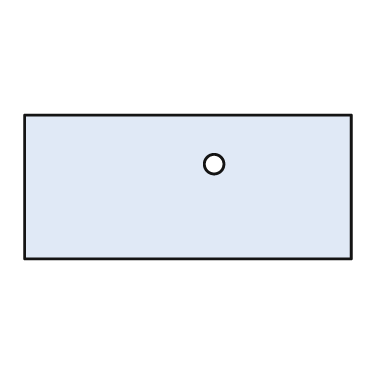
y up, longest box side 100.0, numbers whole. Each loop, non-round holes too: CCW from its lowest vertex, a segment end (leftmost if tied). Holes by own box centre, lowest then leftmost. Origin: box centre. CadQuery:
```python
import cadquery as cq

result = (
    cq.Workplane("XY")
    .moveTo(-50.0, -22.0)
    .lineTo(50.0, -22.0)
    .lineTo(50.0, 22.0)
    .lineTo(-50.0, 22.0)
    .close()
    .moveTo(8.0, 7.0)
    .circle(3.0)
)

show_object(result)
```